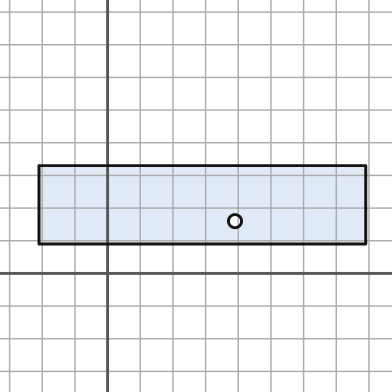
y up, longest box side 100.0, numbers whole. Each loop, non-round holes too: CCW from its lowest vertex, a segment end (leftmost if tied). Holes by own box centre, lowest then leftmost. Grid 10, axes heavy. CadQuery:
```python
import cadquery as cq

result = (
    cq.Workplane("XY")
    .moveTo(-21.0, 9.0)
    .lineTo(79.0, 9.0)
    .lineTo(79.0, 33.0)
    .lineTo(-21.0, 33.0)
    .close()
    .moveTo(39.0, 16.0)
    .circle(2.0)
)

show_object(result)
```